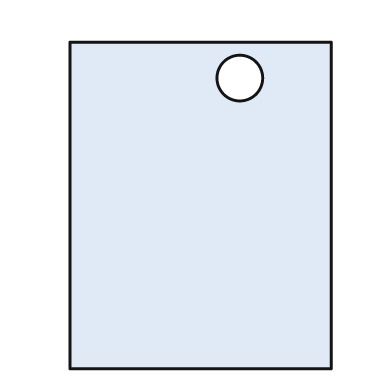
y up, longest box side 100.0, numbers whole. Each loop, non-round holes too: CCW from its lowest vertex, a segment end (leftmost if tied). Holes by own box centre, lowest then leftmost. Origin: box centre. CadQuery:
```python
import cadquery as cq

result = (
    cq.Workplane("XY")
    .moveTo(-40.0, -50.0)
    .lineTo(40.0, -50.0)
    .lineTo(40.0, 50.0)
    .lineTo(-40.0, 50.0)
    .close()
    .moveTo(12.0, 39.0)
    .circle(7.0)
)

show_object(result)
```